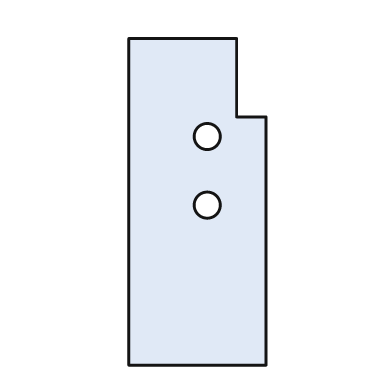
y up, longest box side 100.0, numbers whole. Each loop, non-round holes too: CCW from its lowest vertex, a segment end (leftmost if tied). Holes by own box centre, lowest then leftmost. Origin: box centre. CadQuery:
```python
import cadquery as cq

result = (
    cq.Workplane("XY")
    .moveTo(-21.0, -50.0)
    .lineTo(21.0, -50.0)
    .lineTo(21.0, 26.0)
    .lineTo(12.0, 26.0)
    .lineTo(12.0, 50.0)
    .lineTo(-21.0, 50.0)
    .close()
    .moveTo(3.0, -1.0)
    .circle(4.0)
    .moveTo(3.0, 20.0)
    .circle(4.0)
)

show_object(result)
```